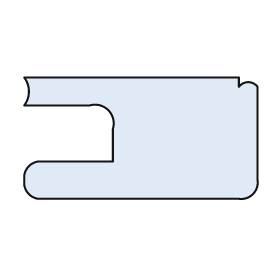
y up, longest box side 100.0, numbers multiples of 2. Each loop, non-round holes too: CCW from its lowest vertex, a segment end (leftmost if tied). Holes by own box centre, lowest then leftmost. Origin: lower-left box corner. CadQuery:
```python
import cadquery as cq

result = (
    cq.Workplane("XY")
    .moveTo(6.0, 0.0)
    .lineTo(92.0, 0.0)
    .threePointArc((98.0, 2.0), (100.0, 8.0))
    .lineTo(100.0, 48.0)
    .threePointArc((96.0, 50.0), (92.0, 48.0))
    .lineTo(92.0, 52.0)
    .lineTo(0.0, 52.0)
    .threePointArc((2.0, 46.0), (0.0, 40.0))
    .lineTo(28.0, 40.0)
    .threePointArc((36.0, 38.0), (38.0, 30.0))
    .lineTo(38.0, 16.0)
    .lineTo(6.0, 16.0)
    .threePointArc((2.0, 14.0), (0.0, 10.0))
    .lineTo(0.0, 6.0)
    .threePointArc((2.0, 2.0), (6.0, 0.0))
    .close()
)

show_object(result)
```